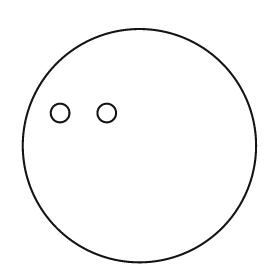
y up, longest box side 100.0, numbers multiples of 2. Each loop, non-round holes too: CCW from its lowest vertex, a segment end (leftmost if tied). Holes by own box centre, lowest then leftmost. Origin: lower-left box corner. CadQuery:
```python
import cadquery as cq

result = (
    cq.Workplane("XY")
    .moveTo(50.0, 50.0)
    .circle(50.0)
    .moveTo(16.0, 64.0)
    .circle(4.0)
    .moveTo(36.0, 64.0)
    .circle(4.0)
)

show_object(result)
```